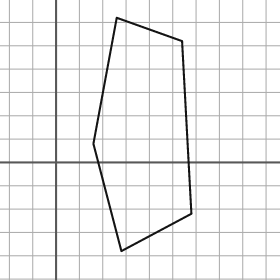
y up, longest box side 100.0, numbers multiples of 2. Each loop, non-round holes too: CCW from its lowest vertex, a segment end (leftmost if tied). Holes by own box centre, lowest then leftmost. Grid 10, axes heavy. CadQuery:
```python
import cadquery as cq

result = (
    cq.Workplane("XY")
    .moveTo(28.0, -38.0)
    .lineTo(58.0, -22.0)
    .lineTo(54.0, 52.0)
    .lineTo(26.0, 62.0)
    .lineTo(16.0, 8.0)
    .close()
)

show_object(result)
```